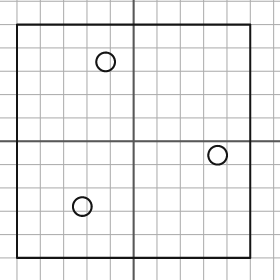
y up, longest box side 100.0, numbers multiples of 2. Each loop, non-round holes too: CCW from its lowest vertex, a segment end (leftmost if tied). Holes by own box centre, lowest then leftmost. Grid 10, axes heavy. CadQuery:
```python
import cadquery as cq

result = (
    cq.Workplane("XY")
    .moveTo(-50.0, -50.0)
    .lineTo(50.0, -50.0)
    .lineTo(50.0, 50.0)
    .lineTo(-50.0, 50.0)
    .close()
    .moveTo(-22.0, -28.0)
    .circle(4.0)
    .moveTo(36.0, -6.0)
    .circle(4.0)
    .moveTo(-12.0, 34.0)
    .circle(4.0)
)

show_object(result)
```